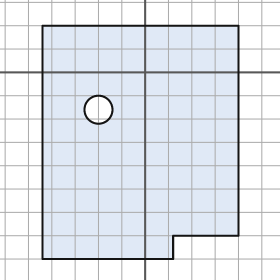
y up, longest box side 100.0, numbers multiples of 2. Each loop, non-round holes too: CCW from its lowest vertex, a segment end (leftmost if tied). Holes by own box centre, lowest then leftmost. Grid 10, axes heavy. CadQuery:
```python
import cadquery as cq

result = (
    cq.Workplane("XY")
    .moveTo(-44.0, -80.0)
    .lineTo(12.0, -80.0)
    .lineTo(12.0, -70.0)
    .lineTo(40.0, -70.0)
    .lineTo(40.0, 20.0)
    .lineTo(-44.0, 20.0)
    .close()
    .moveTo(-20.0, -16.0)
    .circle(6.0)
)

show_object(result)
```